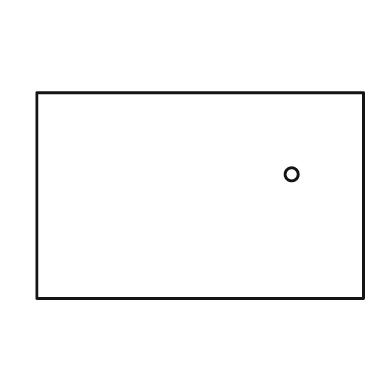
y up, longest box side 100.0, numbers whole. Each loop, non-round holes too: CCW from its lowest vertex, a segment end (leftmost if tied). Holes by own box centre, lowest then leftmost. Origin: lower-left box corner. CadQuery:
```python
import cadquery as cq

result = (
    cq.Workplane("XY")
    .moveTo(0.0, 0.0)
    .lineTo(100.0, 0.0)
    .lineTo(100.0, 63.0)
    .lineTo(0.0, 63.0)
    .close()
    .moveTo(78.0, 38.0)
    .circle(2.0)
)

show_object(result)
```